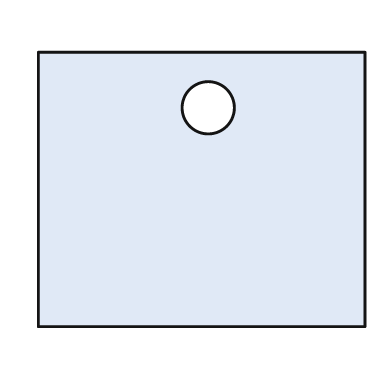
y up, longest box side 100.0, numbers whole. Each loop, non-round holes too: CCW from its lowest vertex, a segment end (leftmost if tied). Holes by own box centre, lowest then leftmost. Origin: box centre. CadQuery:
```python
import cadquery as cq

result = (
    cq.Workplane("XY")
    .moveTo(-50.0, -42.0)
    .lineTo(50.0, -42.0)
    .lineTo(50.0, 42.0)
    .lineTo(-50.0, 42.0)
    .close()
    .moveTo(2.0, 25.0)
    .circle(8.0)
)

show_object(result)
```